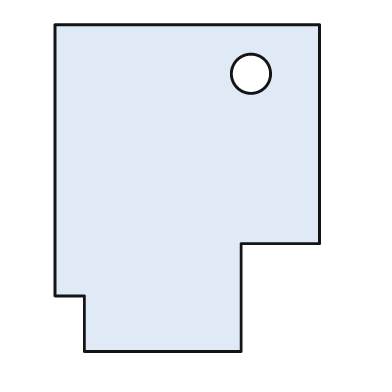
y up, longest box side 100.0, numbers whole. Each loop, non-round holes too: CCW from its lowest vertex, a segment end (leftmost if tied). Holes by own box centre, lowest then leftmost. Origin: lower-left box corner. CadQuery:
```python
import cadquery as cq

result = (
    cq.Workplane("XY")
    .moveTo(9.0, 0.0)
    .lineTo(57.0, 0.0)
    .lineTo(57.0, 33.0)
    .lineTo(81.0, 33.0)
    .lineTo(81.0, 100.0)
    .lineTo(0.0, 100.0)
    .lineTo(0.0, 17.0)
    .lineTo(9.0, 17.0)
    .close()
    .moveTo(60.0, 85.0)
    .circle(6.0)
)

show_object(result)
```